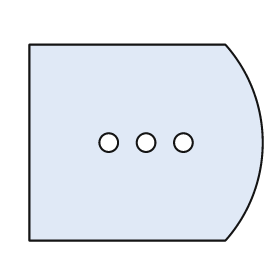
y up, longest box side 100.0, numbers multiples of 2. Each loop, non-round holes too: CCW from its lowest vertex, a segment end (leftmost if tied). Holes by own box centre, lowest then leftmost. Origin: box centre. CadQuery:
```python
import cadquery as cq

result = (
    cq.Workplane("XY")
    .moveTo(-50.0, -42.0)
    .lineTo(34.0, -42.0)
    .threePointArc((50.0, 0.0), (34.0, 42.0))
    .lineTo(-50.0, 42.0)
    .close()
    .moveTo(-16.0, 0.0)
    .circle(4.0)
    .moveTo(0.0, 0.0)
    .circle(4.0)
    .moveTo(16.0, 0.0)
    .circle(4.0)
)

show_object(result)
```